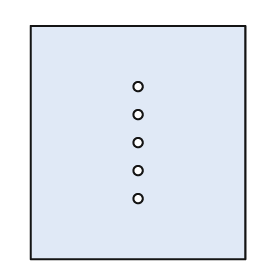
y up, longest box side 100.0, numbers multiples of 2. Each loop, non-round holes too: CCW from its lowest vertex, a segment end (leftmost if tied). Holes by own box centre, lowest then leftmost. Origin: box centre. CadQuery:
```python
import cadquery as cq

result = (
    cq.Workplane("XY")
    .moveTo(-46.0, -50.0)
    .lineTo(46.0, -50.0)
    .lineTo(46.0, 50.0)
    .lineTo(-46.0, 50.0)
    .close()
    .moveTo(0.0, -24.0)
    .circle(2.0)
    .moveTo(0.0, -12.0)
    .circle(2.0)
    .moveTo(0.0, 0.0)
    .circle(2.0)
    .moveTo(0.0, 12.0)
    .circle(2.0)
    .moveTo(0.0, 24.0)
    .circle(2.0)
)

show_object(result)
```